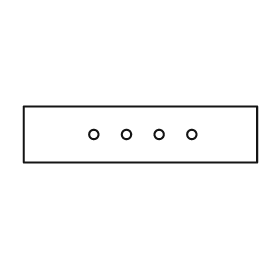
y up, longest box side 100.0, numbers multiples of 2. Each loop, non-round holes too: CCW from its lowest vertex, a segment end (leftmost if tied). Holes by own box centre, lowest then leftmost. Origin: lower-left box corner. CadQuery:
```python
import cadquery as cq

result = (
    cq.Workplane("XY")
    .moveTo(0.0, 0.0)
    .lineTo(100.0, 0.0)
    .lineTo(100.0, 24.0)
    .lineTo(0.0, 24.0)
    .close()
    .moveTo(30.0, 12.0)
    .circle(2.0)
    .moveTo(44.0, 12.0)
    .circle(2.0)
    .moveTo(58.0, 12.0)
    .circle(2.0)
    .moveTo(72.0, 12.0)
    .circle(2.0)
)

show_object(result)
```